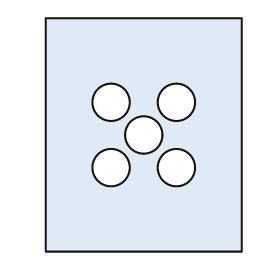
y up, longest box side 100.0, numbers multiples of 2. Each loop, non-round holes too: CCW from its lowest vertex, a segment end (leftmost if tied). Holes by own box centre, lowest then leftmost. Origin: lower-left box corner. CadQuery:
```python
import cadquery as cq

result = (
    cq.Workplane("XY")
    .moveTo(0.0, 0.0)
    .lineTo(84.0, 0.0)
    .lineTo(84.0, 100.0)
    .lineTo(0.0, 100.0)
    .close()
    .moveTo(28.0, 36.0)
    .circle(8.0)
    .moveTo(56.0, 36.0)
    .circle(8.0)
    .moveTo(42.0, 50.0)
    .circle(8.0)
    .moveTo(28.0, 64.0)
    .circle(8.0)
    .moveTo(56.0, 64.0)
    .circle(8.0)
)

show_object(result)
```